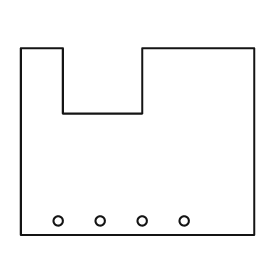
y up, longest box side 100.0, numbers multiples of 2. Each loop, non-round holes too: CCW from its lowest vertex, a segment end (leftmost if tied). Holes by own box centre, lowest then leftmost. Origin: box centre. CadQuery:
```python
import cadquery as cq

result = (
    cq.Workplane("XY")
    .moveTo(-50.0, -40.0)
    .lineTo(50.0, -40.0)
    .lineTo(50.0, 40.0)
    .lineTo(2.0, 40.0)
    .lineTo(2.0, 12.0)
    .lineTo(-32.0, 12.0)
    .lineTo(-32.0, 40.0)
    .lineTo(-50.0, 40.0)
    .close()
    .moveTo(-34.0, -34.0)
    .circle(2.0)
    .moveTo(-16.0, -34.0)
    .circle(2.0)
    .moveTo(2.0, -34.0)
    .circle(2.0)
    .moveTo(20.0, -34.0)
    .circle(2.0)
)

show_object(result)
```